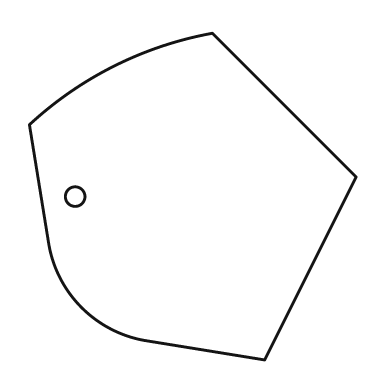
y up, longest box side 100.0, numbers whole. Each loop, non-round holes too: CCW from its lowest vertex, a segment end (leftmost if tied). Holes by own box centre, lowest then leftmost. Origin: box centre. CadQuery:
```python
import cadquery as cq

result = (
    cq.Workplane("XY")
    .moveTo(22.0, -50.0)
    .lineTo(50.0, 6.0)
    .lineTo(6.0, 50.0)
    .threePointArc((-24.0, 40.0), (-50.0, 22.0))
    .lineTo(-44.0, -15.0)
    .threePointArc((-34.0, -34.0), (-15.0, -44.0))
    .close()
    .moveTo(-36.0, 0.0)
    .circle(3.0)
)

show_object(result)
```